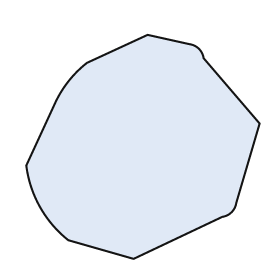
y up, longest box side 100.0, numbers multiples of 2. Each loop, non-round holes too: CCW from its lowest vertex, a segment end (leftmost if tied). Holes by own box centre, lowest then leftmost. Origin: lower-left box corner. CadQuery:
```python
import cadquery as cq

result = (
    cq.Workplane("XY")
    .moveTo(46.0, 0.0)
    .lineTo(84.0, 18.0)
    .threePointArc((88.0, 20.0), (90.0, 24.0))
    .lineTo(100.0, 58.0)
    .lineTo(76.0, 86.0)
    .threePointArc((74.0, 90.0), (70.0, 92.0))
    .lineTo(52.0, 96.0)
    .lineTo(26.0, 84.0)
    .threePointArc((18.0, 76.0), (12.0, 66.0))
    .lineTo(0.0, 40.0)
    .threePointArc((6.0, 22.0), (18.0, 8.0))
    .close()
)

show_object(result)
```